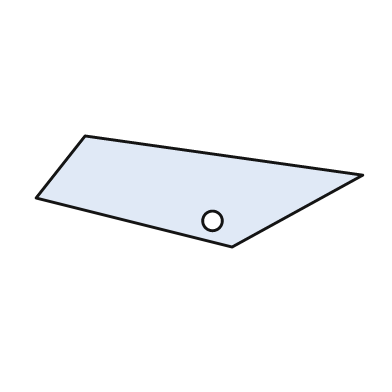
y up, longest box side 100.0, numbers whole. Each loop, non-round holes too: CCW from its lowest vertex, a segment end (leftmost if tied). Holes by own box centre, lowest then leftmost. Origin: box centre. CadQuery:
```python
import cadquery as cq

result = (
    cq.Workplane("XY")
    .moveTo(10.0, -17.0)
    .lineTo(50.0, 5.0)
    .lineTo(-35.0, 17.0)
    .lineTo(-50.0, -2.0)
    .close()
    .moveTo(4.0, -9.0)
    .circle(3.0)
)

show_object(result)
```